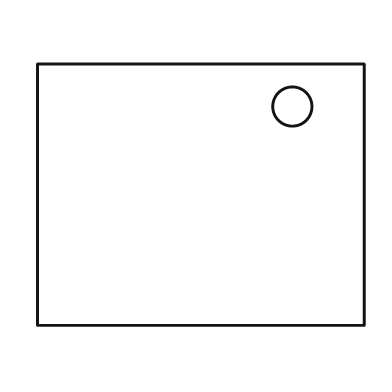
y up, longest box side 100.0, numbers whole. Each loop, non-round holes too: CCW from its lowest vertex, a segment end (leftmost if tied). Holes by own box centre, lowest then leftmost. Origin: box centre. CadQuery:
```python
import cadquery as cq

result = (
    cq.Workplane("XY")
    .moveTo(-50.0, -40.0)
    .lineTo(50.0, -40.0)
    .lineTo(50.0, 40.0)
    .lineTo(-50.0, 40.0)
    .close()
    .moveTo(28.0, 27.0)
    .circle(6.0)
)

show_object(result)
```